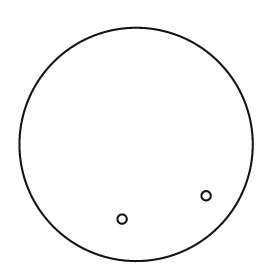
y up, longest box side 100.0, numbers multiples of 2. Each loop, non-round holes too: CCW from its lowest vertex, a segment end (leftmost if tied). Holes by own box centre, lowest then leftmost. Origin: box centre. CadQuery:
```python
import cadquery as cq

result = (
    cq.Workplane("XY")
    .moveTo(0.0, 0.0)
    .circle(50.0)
    .moveTo(-6.0, -32.0)
    .circle(2.0)
    .moveTo(30.0, -22.0)
    .circle(2.0)
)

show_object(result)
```